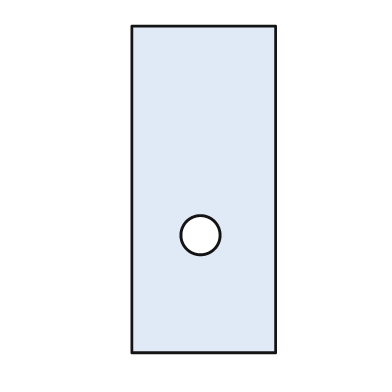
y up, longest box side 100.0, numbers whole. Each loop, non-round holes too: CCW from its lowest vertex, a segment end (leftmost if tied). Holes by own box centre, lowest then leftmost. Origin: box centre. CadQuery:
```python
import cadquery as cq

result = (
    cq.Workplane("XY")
    .moveTo(-22.0, -50.0)
    .lineTo(22.0, -50.0)
    .lineTo(22.0, 50.0)
    .lineTo(-22.0, 50.0)
    .close()
    .moveTo(-1.0, -14.0)
    .circle(6.0)
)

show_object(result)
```